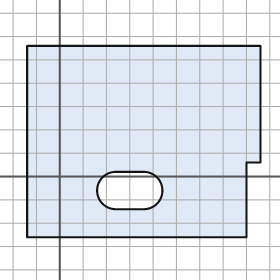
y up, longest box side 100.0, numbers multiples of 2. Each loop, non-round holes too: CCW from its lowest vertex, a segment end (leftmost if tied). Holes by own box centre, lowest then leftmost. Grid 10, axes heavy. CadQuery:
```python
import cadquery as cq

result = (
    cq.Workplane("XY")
    .moveTo(-14.0, -26.0)
    .lineTo(80.0, -26.0)
    .lineTo(80.0, 6.0)
    .lineTo(86.0, 6.0)
    .lineTo(86.0, 56.0)
    .lineTo(-14.0, 56.0)
    .close()
    .moveTo(24.0, -14.0)
    .lineTo(36.0, -14.0)
    .threePointArc((44.0, -6.0), (36.0, 2.0))
    .lineTo(24.0, 2.0)
    .threePointArc((16.0, -6.0), (24.0, -14.0))
    .close()
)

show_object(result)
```